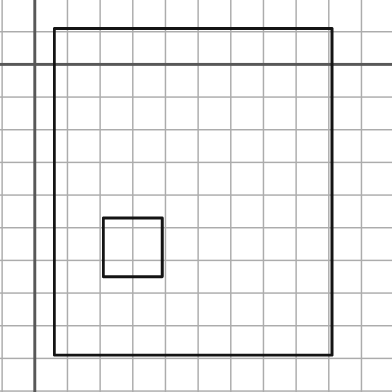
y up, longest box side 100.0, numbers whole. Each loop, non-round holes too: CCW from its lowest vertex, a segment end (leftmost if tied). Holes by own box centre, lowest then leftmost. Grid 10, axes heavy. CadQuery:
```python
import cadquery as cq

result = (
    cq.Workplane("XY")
    .moveTo(6.0, -89.0)
    .lineTo(91.0, -89.0)
    .lineTo(91.0, 11.0)
    .lineTo(6.0, 11.0)
    .close()
    .moveTo(21.0, -65.0)
    .lineTo(39.0, -65.0)
    .lineTo(39.0, -47.0)
    .lineTo(21.0, -47.0)
    .close()
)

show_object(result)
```